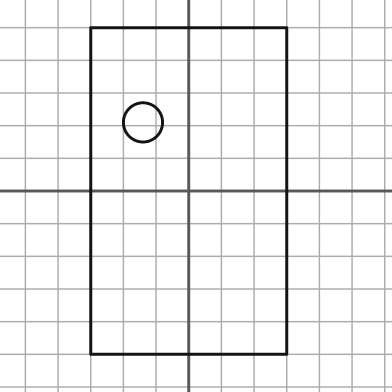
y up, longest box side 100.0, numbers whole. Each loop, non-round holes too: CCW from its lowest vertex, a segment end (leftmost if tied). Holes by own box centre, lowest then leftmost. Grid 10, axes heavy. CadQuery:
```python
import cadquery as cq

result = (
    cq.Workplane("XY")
    .moveTo(-30.0, -50.0)
    .lineTo(30.0, -50.0)
    .lineTo(30.0, 50.0)
    .lineTo(-30.0, 50.0)
    .close()
    .moveTo(-14.0, 21.0)
    .circle(6.0)
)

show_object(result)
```